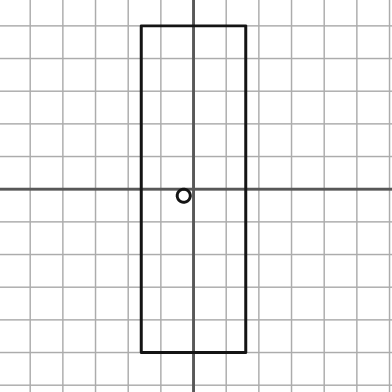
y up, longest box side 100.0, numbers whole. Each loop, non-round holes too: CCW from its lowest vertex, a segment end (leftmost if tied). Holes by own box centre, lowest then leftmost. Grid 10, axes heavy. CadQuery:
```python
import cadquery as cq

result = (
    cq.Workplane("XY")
    .moveTo(-16.0, -50.0)
    .lineTo(16.0, -50.0)
    .lineTo(16.0, 50.0)
    .lineTo(-16.0, 50.0)
    .close()
    .moveTo(-3.0, -2.0)
    .circle(2.0)
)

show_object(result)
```